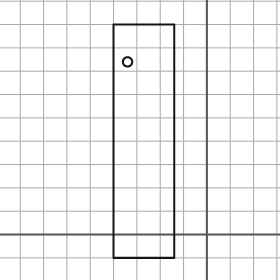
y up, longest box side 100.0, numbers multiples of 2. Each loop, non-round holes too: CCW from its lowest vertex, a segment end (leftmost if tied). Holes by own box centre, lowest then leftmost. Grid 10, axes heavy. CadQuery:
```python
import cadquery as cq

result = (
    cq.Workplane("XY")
    .moveTo(-40.0, -10.0)
    .lineTo(-14.0, -10.0)
    .lineTo(-14.0, 90.0)
    .lineTo(-40.0, 90.0)
    .close()
    .moveTo(-34.0, 74.0)
    .circle(2.0)
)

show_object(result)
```